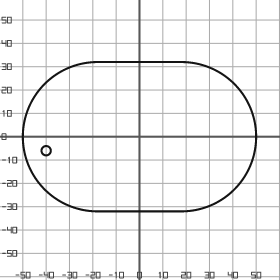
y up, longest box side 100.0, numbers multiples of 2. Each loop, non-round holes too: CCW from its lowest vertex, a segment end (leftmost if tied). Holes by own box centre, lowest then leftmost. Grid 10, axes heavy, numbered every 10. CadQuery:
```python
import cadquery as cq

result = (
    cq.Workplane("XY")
    .moveTo(-18.0, -32.0)
    .lineTo(18.0, -32.0)
    .threePointArc((50.0, 0.0), (18.0, 32.0))
    .lineTo(-18.0, 32.0)
    .threePointArc((-50.0, 0.0), (-18.0, -32.0))
    .close()
    .moveTo(-40.0, -6.0)
    .circle(2.0)
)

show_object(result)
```